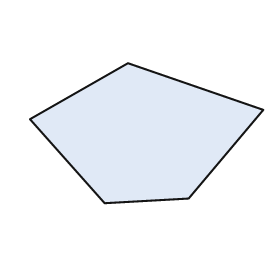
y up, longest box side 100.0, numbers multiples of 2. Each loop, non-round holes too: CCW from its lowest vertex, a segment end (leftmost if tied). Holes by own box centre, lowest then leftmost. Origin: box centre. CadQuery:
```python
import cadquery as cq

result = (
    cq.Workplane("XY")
    .moveTo(-18.0, -30.0)
    .lineTo(18.0, -28.0)
    .lineTo(50.0, 10.0)
    .lineTo(-8.0, 30.0)
    .lineTo(-50.0, 6.0)
    .close()
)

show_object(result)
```